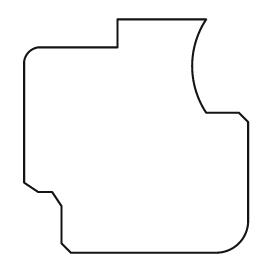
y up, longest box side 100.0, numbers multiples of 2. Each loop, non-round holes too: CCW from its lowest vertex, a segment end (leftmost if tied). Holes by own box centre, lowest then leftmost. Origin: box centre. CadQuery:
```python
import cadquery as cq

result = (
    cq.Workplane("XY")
    .moveTo(-28.0, -50.0)
    .lineTo(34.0, -50.0)
    .threePointArc((44.0, -46.0), (48.0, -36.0))
    .lineTo(48.0, 6.0)
    .lineTo(44.0, 10.0)
    .lineTo(30.0, 10.0)
    .threePointArc((24.0, 30.0), (30.0, 50.0))
    .lineTo(-8.0, 50.0)
    .lineTo(-8.0, 38.0)
    .lineTo(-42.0, 38.0)
    .threePointArc((-46.0, 36.0), (-48.0, 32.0))
    .lineTo(-48.0, -20.0)
    .lineTo(-42.0, -24.0)
    .lineTo(-36.0, -24.0)
    .lineTo(-32.0, -30.0)
    .lineTo(-32.0, -46.0)
    .close()
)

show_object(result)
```